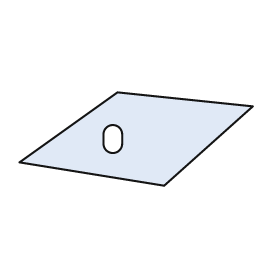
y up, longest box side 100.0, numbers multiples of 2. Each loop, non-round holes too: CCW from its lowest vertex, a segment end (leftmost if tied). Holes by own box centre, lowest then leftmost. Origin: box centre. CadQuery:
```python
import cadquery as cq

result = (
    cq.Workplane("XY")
    .moveTo(12.0, -20.0)
    .lineTo(50.0, 14.0)
    .lineTo(-8.0, 20.0)
    .lineTo(-50.0, -10.0)
    .close()
    .moveTo(-14.0, -2.0)
    .threePointArc((-10.0, -6.0), (-6.0, -2.0))
    .lineTo(-6.0, 2.0)
    .threePointArc((-10.0, 6.0), (-14.0, 2.0))
    .close()
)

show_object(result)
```